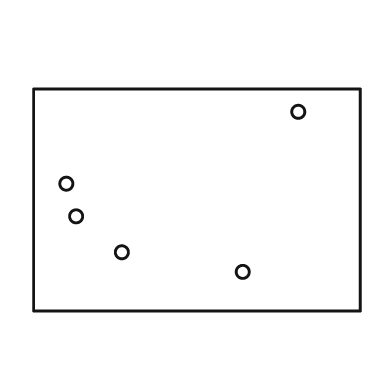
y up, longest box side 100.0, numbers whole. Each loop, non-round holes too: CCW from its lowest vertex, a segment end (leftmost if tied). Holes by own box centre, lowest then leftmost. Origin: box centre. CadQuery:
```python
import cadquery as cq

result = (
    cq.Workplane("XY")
    .moveTo(-50.0, -34.0)
    .lineTo(50.0, -34.0)
    .lineTo(50.0, 34.0)
    .lineTo(-50.0, 34.0)
    .close()
    .moveTo(14.0, -22.0)
    .circle(2.0)
    .moveTo(-23.0, -16.0)
    .circle(2.0)
    .moveTo(-37.0, -5.0)
    .circle(2.0)
    .moveTo(-40.0, 5.0)
    .circle(2.0)
    .moveTo(31.0, 27.0)
    .circle(2.0)
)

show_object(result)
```